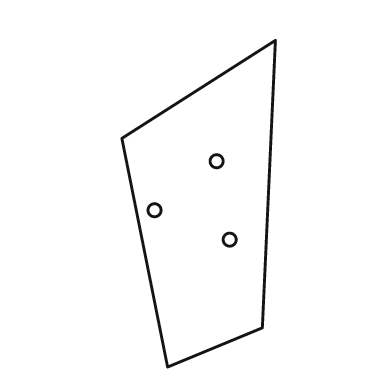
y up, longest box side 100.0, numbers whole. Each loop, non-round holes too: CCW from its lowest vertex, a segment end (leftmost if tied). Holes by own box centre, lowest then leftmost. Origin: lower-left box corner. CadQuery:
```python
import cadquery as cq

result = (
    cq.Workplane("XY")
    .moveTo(14.0, 0.0)
    .lineTo(43.0, 12.0)
    .lineTo(47.0, 100.0)
    .lineTo(0.0, 70.0)
    .close()
    .moveTo(33.0, 39.0)
    .circle(2.0)
    .moveTo(10.0, 48.0)
    .circle(2.0)
    .moveTo(29.0, 63.0)
    .circle(2.0)
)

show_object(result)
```